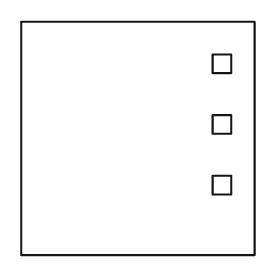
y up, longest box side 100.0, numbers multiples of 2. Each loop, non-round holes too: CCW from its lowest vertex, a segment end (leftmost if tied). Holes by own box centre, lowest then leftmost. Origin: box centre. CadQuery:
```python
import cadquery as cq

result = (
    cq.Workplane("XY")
    .moveTo(-50.0, -50.0)
    .lineTo(50.0, -50.0)
    .lineTo(50.0, 50.0)
    .lineTo(-50.0, 50.0)
    .close()
    .moveTo(32.0, -24.0)
    .lineTo(40.0, -24.0)
    .lineTo(40.0, -16.0)
    .lineTo(32.0, -16.0)
    .close()
    .moveTo(32.0, 2.0)
    .lineTo(40.0, 2.0)
    .lineTo(40.0, 10.0)
    .lineTo(32.0, 10.0)
    .close()
    .moveTo(32.0, 28.0)
    .lineTo(40.0, 28.0)
    .lineTo(40.0, 36.0)
    .lineTo(32.0, 36.0)
    .close()
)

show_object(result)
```